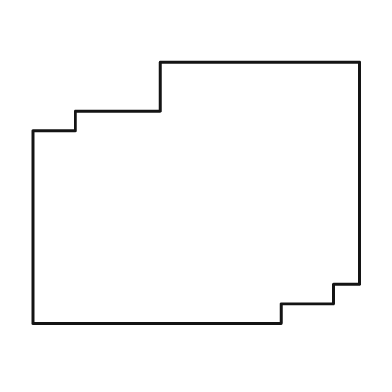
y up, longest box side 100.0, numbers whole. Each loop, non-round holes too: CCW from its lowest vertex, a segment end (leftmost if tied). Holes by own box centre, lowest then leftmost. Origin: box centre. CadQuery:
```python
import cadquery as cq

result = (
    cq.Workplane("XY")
    .moveTo(-50.0, -40.0)
    .lineTo(26.0, -40.0)
    .lineTo(26.0, -34.0)
    .lineTo(42.0, -34.0)
    .lineTo(42.0, -28.0)
    .lineTo(50.0, -28.0)
    .lineTo(50.0, 40.0)
    .lineTo(-11.0, 40.0)
    .lineTo(-11.0, 25.0)
    .lineTo(-37.0, 25.0)
    .lineTo(-37.0, 19.0)
    .lineTo(-50.0, 19.0)
    .close()
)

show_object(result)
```